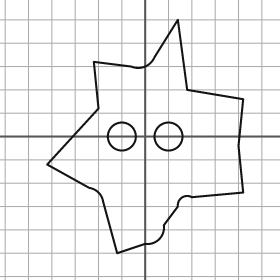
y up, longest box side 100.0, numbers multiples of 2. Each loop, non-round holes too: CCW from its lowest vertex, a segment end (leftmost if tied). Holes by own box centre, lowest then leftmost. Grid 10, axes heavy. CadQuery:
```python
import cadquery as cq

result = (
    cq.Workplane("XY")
    .moveTo(-12.0, -50.0)
    .lineTo(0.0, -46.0)
    .threePointArc((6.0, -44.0), (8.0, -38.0))
    .lineTo(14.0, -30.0)
    .threePointArc((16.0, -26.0), (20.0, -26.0))
    .lineTo(42.0, -24.0)
    .lineTo(40.0, -4.0)
    .lineTo(42.0, 16.0)
    .lineTo(18.0, 20.0)
    .lineTo(14.0, 50.0)
    .lineTo(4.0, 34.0)
    .threePointArc((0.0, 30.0), (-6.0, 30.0))
    .lineTo(-22.0, 32.0)
    .lineTo(-20.0, 12.0)
    .lineTo(-42.0, -12.0)
    .lineTo(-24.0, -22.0)
    .threePointArc((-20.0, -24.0), (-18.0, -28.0))
    .close()
    .moveTo(-10.0, 0.0)
    .circle(6.0)
    .moveTo(10.0, 0.0)
    .circle(6.0)
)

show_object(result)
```